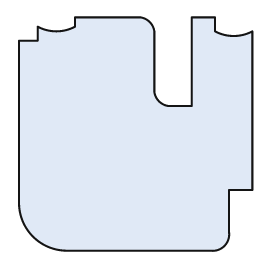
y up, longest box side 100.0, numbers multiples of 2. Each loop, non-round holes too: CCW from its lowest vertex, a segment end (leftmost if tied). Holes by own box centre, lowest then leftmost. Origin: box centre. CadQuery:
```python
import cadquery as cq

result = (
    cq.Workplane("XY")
    .moveTo(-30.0, -50.0)
    .lineTo(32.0, -50.0)
    .threePointArc((38.0, -48.0), (40.0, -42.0))
    .lineTo(40.0, -24.0)
    .lineTo(50.0, -24.0)
    .lineTo(50.0, 44.0)
    .threePointArc((42.0, 42.0), (34.0, 44.0))
    .lineTo(34.0, 50.0)
    .lineTo(24.0, 50.0)
    .lineTo(24.0, 12.0)
    .lineTo(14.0, 12.0)
    .threePointArc((10.0, 14.0), (8.0, 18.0))
    .lineTo(8.0, 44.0)
    .threePointArc((6.0, 48.0), (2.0, 50.0))
    .lineTo(-26.0, 50.0)
    .lineTo(-26.0, 46.0)
    .threePointArc((-34.0, 44.0), (-42.0, 46.0))
    .lineTo(-42.0, 40.0)
    .lineTo(-50.0, 40.0)
    .lineTo(-50.0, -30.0)
    .threePointArc((-44.0, -44.0), (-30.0, -50.0))
    .close()
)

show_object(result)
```